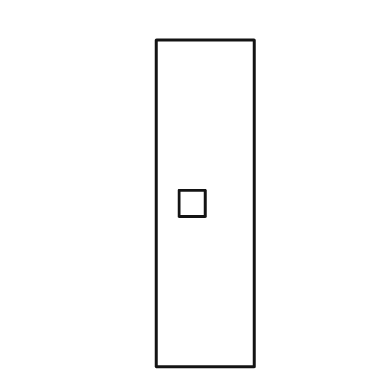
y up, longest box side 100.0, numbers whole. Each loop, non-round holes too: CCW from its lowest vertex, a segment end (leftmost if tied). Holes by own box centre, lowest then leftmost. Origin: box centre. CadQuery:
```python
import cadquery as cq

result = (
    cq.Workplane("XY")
    .moveTo(-15.0, -50.0)
    .lineTo(15.0, -50.0)
    .lineTo(15.0, 50.0)
    .lineTo(-15.0, 50.0)
    .close()
    .moveTo(-8.0, -4.0)
    .lineTo(0.0, -4.0)
    .lineTo(0.0, 4.0)
    .lineTo(-8.0, 4.0)
    .close()
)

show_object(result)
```